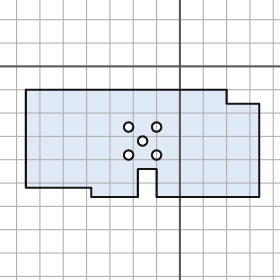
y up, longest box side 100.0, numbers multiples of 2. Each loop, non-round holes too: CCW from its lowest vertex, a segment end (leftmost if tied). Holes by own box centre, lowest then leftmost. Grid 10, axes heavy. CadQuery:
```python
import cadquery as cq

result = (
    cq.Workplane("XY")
    .moveTo(-38.0, -56.0)
    .lineTo(-18.0, -56.0)
    .lineTo(-18.0, -44.0)
    .lineTo(-10.0, -44.0)
    .lineTo(-10.0, -56.0)
    .lineTo(34.0, -56.0)
    .lineTo(34.0, -16.0)
    .lineTo(20.0, -16.0)
    .lineTo(20.0, -10.0)
    .lineTo(-66.0, -10.0)
    .lineTo(-66.0, -52.0)
    .lineTo(-38.0, -52.0)
    .close()
    .moveTo(-22.0, -38.0)
    .circle(2.0)
    .moveTo(-10.0, -38.0)
    .circle(2.0)
    .moveTo(-16.0, -32.0)
    .circle(2.0)
    .moveTo(-22.0, -26.0)
    .circle(2.0)
    .moveTo(-10.0, -26.0)
    .circle(2.0)
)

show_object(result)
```